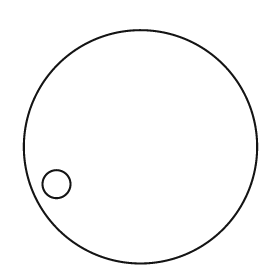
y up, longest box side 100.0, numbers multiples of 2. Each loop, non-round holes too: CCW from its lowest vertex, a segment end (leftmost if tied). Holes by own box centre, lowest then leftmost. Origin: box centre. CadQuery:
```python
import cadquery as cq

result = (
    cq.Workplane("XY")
    .moveTo(0.0, 0.0)
    .circle(50.0)
    .moveTo(-36.0, -16.0)
    .circle(6.0)
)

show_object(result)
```